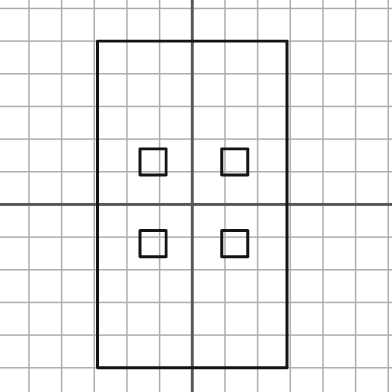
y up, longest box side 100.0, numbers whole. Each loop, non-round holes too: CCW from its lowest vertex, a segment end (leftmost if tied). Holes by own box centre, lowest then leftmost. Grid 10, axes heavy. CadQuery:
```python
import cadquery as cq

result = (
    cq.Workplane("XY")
    .moveTo(-29.0, -50.0)
    .lineTo(29.0, -50.0)
    .lineTo(29.0, 50.0)
    .lineTo(-29.0, 50.0)
    .close()
    .moveTo(-16.0, -16.0)
    .lineTo(-8.0, -16.0)
    .lineTo(-8.0, -8.0)
    .lineTo(-16.0, -8.0)
    .close()
    .moveTo(9.0, -16.0)
    .lineTo(17.0, -16.0)
    .lineTo(17.0, -8.0)
    .lineTo(9.0, -8.0)
    .close()
    .moveTo(-16.0, 9.0)
    .lineTo(-8.0, 9.0)
    .lineTo(-8.0, 17.0)
    .lineTo(-16.0, 17.0)
    .close()
    .moveTo(9.0, 9.0)
    .lineTo(17.0, 9.0)
    .lineTo(17.0, 17.0)
    .lineTo(9.0, 17.0)
    .close()
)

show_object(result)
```